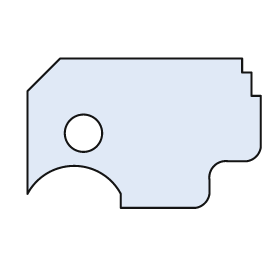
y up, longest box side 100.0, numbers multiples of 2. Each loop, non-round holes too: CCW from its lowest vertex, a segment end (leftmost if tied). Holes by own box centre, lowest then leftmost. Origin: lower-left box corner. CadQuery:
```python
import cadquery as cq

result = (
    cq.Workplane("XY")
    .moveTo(40.0, 0.0)
    .lineTo(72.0, 0.0)
    .threePointArc((76.0, 2.0), (78.0, 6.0))
    .lineTo(78.0, 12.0)
    .threePointArc((80.0, 18.0), (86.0, 20.0))
    .lineTo(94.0, 20.0)
    .threePointArc((98.0, 22.0), (100.0, 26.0))
    .lineTo(100.0, 48.0)
    .lineTo(96.0, 48.0)
    .lineTo(96.0, 58.0)
    .lineTo(92.0, 58.0)
    .lineTo(92.0, 64.0)
    .lineTo(14.0, 64.0)
    .lineTo(0.0, 50.0)
    .lineTo(0.0, 6.0)
    .threePointArc((20.0, 18.0), (40.0, 6.0))
    .close()
    .moveTo(24.0, 32.0)
    .circle(8.0)
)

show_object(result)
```